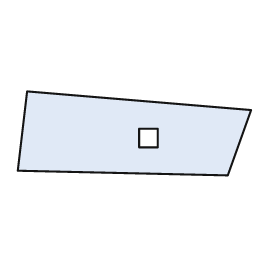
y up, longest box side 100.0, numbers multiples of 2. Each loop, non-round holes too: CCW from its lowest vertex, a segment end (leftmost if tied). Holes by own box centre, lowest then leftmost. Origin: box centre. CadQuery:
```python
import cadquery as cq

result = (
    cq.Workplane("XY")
    .moveTo(40.0, -18.0)
    .lineTo(50.0, 10.0)
    .lineTo(-46.0, 18.0)
    .lineTo(-50.0, -16.0)
    .close()
    .moveTo(2.0, -6.0)
    .lineTo(10.0, -6.0)
    .lineTo(10.0, 2.0)
    .lineTo(2.0, 2.0)
    .close()
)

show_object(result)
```